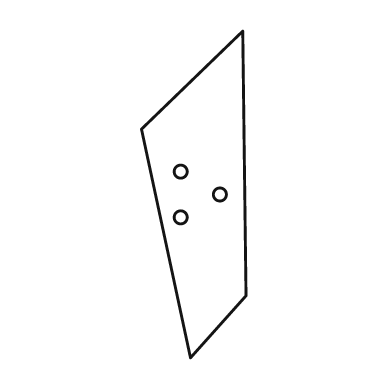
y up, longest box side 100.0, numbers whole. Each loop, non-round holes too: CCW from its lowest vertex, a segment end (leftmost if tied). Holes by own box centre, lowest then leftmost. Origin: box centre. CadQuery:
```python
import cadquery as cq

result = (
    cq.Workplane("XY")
    .moveTo(-1.0, -50.0)
    .lineTo(16.0, -31.0)
    .lineTo(15.0, 50.0)
    .lineTo(-16.0, 20.0)
    .close()
    .moveTo(-4.0, -7.0)
    .circle(2.0)
    .moveTo(8.0, 0.0)
    .circle(2.0)
    .moveTo(-4.0, 7.0)
    .circle(2.0)
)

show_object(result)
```